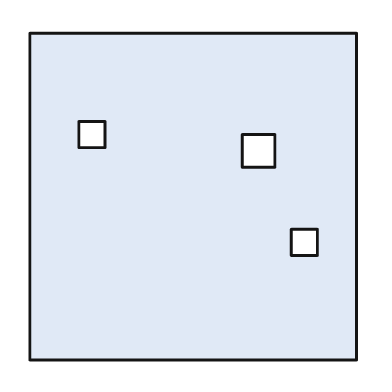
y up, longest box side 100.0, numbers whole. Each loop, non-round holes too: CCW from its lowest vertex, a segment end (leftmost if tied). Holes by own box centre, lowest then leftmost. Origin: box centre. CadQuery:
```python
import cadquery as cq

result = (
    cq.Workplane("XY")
    .moveTo(-50.0, -50.0)
    .lineTo(50.0, -50.0)
    .lineTo(50.0, 50.0)
    .lineTo(-50.0, 50.0)
    .close()
    .moveTo(30.0, -18.0)
    .lineTo(38.0, -18.0)
    .lineTo(38.0, -10.0)
    .lineTo(30.0, -10.0)
    .close()
    .moveTo(15.0, 9.0)
    .lineTo(25.0, 9.0)
    .lineTo(25.0, 19.0)
    .lineTo(15.0, 19.0)
    .close()
    .moveTo(-35.0, 15.0)
    .lineTo(-27.0, 15.0)
    .lineTo(-27.0, 23.0)
    .lineTo(-35.0, 23.0)
    .close()
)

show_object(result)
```